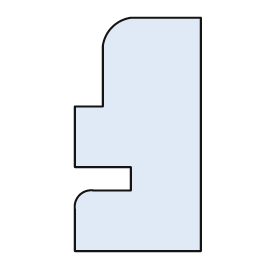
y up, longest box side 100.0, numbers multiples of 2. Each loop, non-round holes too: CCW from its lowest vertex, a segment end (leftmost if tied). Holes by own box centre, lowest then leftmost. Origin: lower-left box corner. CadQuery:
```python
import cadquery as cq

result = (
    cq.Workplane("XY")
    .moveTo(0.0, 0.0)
    .lineTo(54.0, 0.0)
    .lineTo(54.0, 100.0)
    .lineTo(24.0, 100.0)
    .threePointArc((16.0, 96.0), (12.0, 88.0))
    .lineTo(12.0, 62.0)
    .lineTo(0.0, 62.0)
    .lineTo(0.0, 36.0)
    .lineTo(24.0, 36.0)
    .lineTo(24.0, 26.0)
    .lineTo(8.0, 26.0)
    .threePointArc((2.0, 24.0), (0.0, 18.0))
    .close()
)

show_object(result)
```